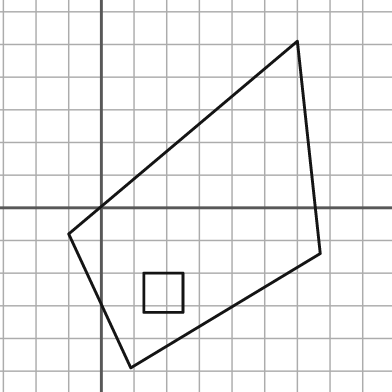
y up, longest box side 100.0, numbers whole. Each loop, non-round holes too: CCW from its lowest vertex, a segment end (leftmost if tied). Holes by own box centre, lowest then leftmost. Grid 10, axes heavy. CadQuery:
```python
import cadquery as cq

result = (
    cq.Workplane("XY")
    .moveTo(9.0, -49.0)
    .lineTo(67.0, -14.0)
    .lineTo(60.0, 51.0)
    .lineTo(-10.0, -8.0)
    .close()
    .moveTo(13.0, -32.0)
    .lineTo(25.0, -32.0)
    .lineTo(25.0, -20.0)
    .lineTo(13.0, -20.0)
    .close()
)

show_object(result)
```